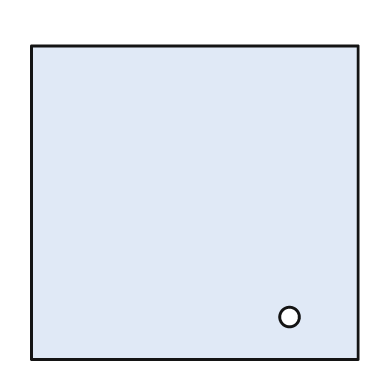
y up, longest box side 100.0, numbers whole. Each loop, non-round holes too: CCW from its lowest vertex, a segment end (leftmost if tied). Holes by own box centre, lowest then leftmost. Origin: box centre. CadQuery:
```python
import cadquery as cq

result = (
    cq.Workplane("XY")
    .moveTo(-50.0, -48.0)
    .lineTo(50.0, -48.0)
    .lineTo(50.0, 48.0)
    .lineTo(-50.0, 48.0)
    .close()
    .moveTo(29.0, -35.0)
    .circle(3.0)
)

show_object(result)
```